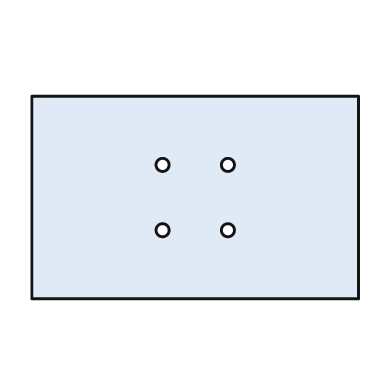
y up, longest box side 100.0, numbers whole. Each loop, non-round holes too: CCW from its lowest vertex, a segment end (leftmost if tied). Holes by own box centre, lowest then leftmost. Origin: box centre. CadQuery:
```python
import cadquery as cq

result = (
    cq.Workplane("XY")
    .moveTo(-50.0, -31.0)
    .lineTo(50.0, -31.0)
    .lineTo(50.0, 31.0)
    .lineTo(-50.0, 31.0)
    .close()
    .moveTo(-10.0, -10.0)
    .circle(2.0)
    .moveTo(10.0, -10.0)
    .circle(2.0)
    .moveTo(-10.0, 10.0)
    .circle(2.0)
    .moveTo(10.0, 10.0)
    .circle(2.0)
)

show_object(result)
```